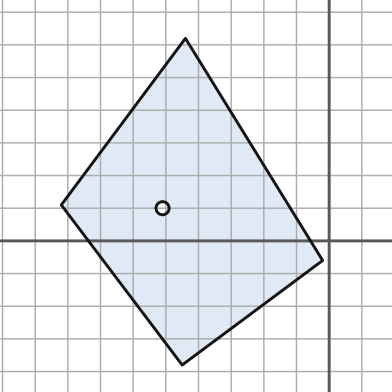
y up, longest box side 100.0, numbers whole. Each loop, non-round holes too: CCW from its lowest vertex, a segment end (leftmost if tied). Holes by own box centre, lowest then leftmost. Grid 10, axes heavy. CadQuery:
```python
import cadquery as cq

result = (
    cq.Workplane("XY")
    .moveTo(-45.0, -38.0)
    .lineTo(-2.0, -6.0)
    .lineTo(-44.0, 62.0)
    .lineTo(-82.0, 11.0)
    .close()
    .moveTo(-51.0, 10.0)
    .circle(2.0)
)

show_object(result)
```